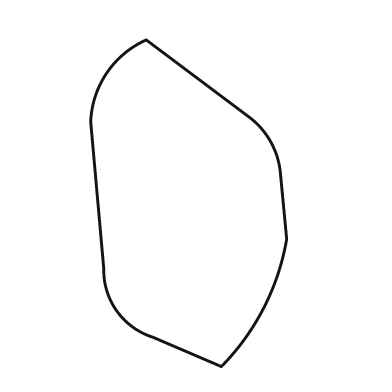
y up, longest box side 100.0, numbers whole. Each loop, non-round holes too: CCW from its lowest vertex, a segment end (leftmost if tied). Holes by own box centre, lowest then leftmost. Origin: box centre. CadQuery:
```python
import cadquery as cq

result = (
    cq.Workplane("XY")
    .moveTo(10.0, -50.0)
    .threePointArc((23.0, -32.0), (30.0, -11.0))
    .lineTo(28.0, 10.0)
    .threePointArc((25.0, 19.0), (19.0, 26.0))
    .lineTo(-13.0, 50.0)
    .threePointArc((-25.0, 40.0), (-30.0, 25.0))
    .lineTo(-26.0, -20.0)
    .threePointArc((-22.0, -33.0), (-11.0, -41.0))
    .close()
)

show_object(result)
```